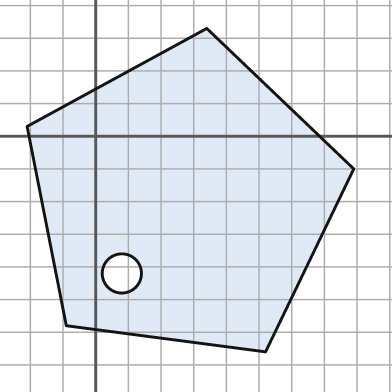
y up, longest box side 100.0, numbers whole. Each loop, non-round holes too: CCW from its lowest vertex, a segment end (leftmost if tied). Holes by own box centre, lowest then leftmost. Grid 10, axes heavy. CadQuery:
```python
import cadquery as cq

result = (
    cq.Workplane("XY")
    .moveTo(52.0, -66.0)
    .lineTo(79.0, -10.0)
    .lineTo(34.0, 33.0)
    .lineTo(-21.0, 3.0)
    .lineTo(-9.0, -58.0)
    .close()
    .moveTo(8.0, -42.0)
    .circle(6.0)
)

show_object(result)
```